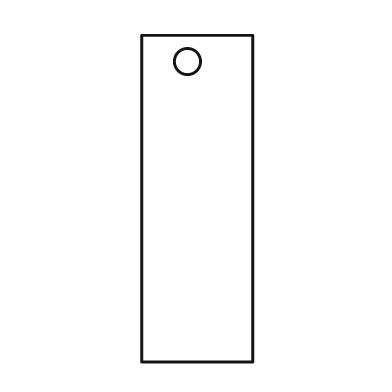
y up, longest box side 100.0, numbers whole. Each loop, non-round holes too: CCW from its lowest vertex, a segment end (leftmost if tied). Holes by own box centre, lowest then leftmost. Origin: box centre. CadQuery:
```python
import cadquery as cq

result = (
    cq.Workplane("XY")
    .moveTo(-17.0, -50.0)
    .lineTo(17.0, -50.0)
    .lineTo(17.0, 50.0)
    .lineTo(-17.0, 50.0)
    .close()
    .moveTo(-3.0, 42.0)
    .circle(4.0)
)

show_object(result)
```